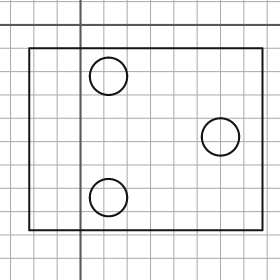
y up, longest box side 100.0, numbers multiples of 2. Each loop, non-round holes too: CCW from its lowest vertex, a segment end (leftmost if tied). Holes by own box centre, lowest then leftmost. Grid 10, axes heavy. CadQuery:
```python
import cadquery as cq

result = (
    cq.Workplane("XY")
    .moveTo(-22.0, -88.0)
    .lineTo(78.0, -88.0)
    .lineTo(78.0, -10.0)
    .lineTo(-22.0, -10.0)
    .close()
    .moveTo(12.0, -74.0)
    .circle(8.0)
    .moveTo(60.0, -48.0)
    .circle(8.0)
    .moveTo(12.0, -22.0)
    .circle(8.0)
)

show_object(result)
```